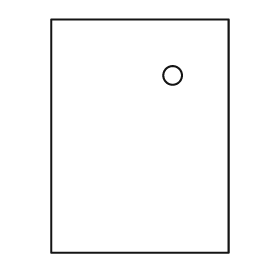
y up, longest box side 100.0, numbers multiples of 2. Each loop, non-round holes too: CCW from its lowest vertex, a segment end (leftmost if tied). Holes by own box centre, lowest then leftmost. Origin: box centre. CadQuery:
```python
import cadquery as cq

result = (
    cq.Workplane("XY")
    .moveTo(-38.0, -50.0)
    .lineTo(38.0, -50.0)
    .lineTo(38.0, 50.0)
    .lineTo(-38.0, 50.0)
    .close()
    .moveTo(14.0, 26.0)
    .circle(4.0)
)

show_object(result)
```